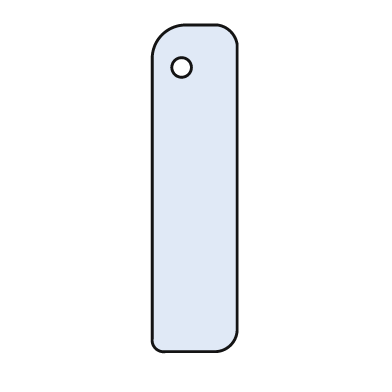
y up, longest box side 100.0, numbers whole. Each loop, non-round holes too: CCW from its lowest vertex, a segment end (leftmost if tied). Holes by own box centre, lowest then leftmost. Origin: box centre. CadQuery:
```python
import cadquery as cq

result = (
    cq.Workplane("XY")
    .moveTo(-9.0, -50.0)
    .lineTo(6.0, -50.0)
    .threePointArc((11.0, -48.0), (13.0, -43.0))
    .lineTo(13.0, 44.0)
    .threePointArc((11.0, 48.0), (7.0, 50.0))
    .lineTo(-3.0, 50.0)
    .threePointArc((-10.0, 47.0), (-13.0, 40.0))
    .lineTo(-13.0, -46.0)
    .threePointArc((-12.0, -49.0), (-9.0, -50.0))
    .close()
    .moveTo(-4.0, 37.0)
    .circle(3.0)
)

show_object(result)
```